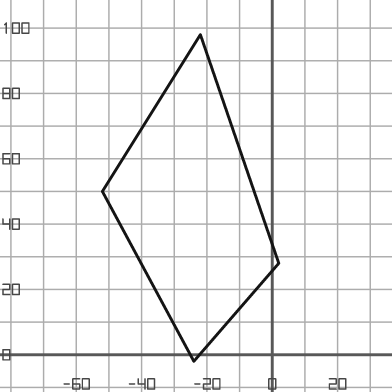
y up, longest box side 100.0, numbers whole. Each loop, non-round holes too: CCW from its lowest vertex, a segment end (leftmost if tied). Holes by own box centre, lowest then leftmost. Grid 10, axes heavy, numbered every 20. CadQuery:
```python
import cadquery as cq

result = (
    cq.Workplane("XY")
    .moveTo(-24.0, -2.0)
    .lineTo(2.0, 28.0)
    .lineTo(-22.0, 98.0)
    .lineTo(-52.0, 50.0)
    .close()
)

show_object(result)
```